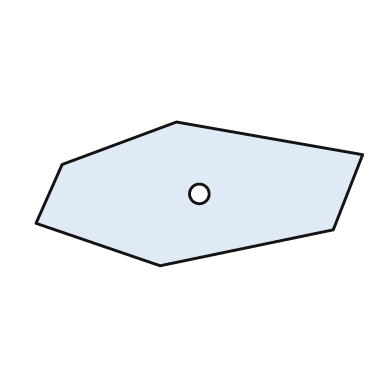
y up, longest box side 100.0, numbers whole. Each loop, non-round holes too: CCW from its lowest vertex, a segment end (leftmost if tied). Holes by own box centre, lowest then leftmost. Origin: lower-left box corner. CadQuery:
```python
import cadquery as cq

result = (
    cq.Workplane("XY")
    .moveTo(38.0, 0.0)
    .lineTo(91.0, 11.0)
    .lineTo(100.0, 34.0)
    .lineTo(43.0, 44.0)
    .lineTo(8.0, 31.0)
    .lineTo(0.0, 13.0)
    .close()
    .moveTo(50.0, 22.0)
    .circle(3.0)
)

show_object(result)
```